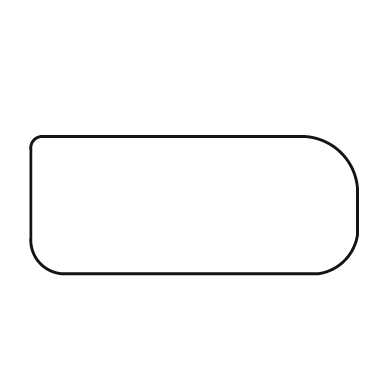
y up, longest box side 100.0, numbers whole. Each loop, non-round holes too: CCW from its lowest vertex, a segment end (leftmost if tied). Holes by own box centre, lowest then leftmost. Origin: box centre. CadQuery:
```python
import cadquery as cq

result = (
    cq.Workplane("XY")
    .moveTo(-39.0, -21.0)
    .lineTo(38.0, -21.0)
    .threePointArc((46.0, -17.0), (50.0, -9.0))
    .lineTo(50.0, 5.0)
    .threePointArc((45.0, 16.0), (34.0, 21.0))
    .lineTo(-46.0, 21.0)
    .threePointArc((-49.0, 20.0), (-50.0, 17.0))
    .lineTo(-50.0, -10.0)
    .threePointArc((-47.0, -18.0), (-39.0, -21.0))
    .close()
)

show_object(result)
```